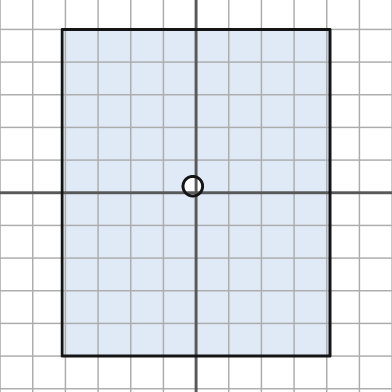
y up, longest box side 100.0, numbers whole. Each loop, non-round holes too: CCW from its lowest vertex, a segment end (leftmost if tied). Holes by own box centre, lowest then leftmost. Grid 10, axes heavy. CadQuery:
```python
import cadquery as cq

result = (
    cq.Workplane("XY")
    .moveTo(-41.0, -50.0)
    .lineTo(41.0, -50.0)
    .lineTo(41.0, 50.0)
    .lineTo(-41.0, 50.0)
    .close()
    .moveTo(-1.0, 2.0)
    .circle(3.0)
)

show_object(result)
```